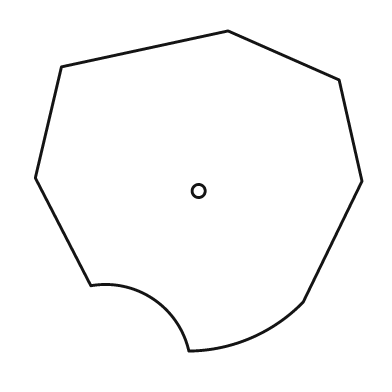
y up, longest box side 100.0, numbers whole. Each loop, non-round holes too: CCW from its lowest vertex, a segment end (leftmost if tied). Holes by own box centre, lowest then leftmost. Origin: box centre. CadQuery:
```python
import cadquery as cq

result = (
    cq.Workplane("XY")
    .moveTo(-3.0, -49.0)
    .threePointArc((16.0, -45.0), (32.0, -34.0))
    .lineTo(50.0, 3.0)
    .lineTo(43.0, 34.0)
    .lineTo(9.0, 49.0)
    .lineTo(-42.0, 38.0)
    .lineTo(-50.0, 4.0)
    .lineTo(-33.0, -29.0)
    .threePointArc((-14.0, -33.0), (-3.0, -49.0))
    .close()
    .moveTo(0.0, 0.0)
    .circle(2.0)
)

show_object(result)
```